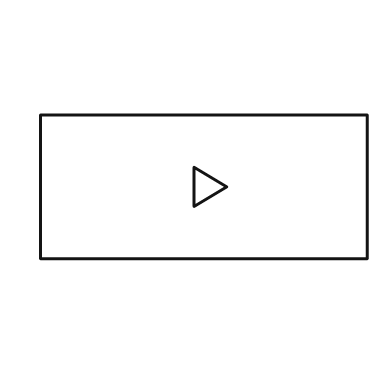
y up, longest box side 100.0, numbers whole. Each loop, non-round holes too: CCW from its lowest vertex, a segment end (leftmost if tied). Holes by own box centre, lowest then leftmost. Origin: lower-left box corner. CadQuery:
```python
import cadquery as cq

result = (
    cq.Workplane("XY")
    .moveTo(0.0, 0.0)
    .lineTo(100.0, 0.0)
    .lineTo(100.0, 44.0)
    .lineTo(0.0, 44.0)
    .close()
    .moveTo(47.0, 16.0)
    .lineTo(57.0, 22.0)
    .lineTo(47.0, 28.0)
    .close()
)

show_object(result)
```